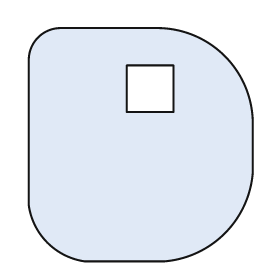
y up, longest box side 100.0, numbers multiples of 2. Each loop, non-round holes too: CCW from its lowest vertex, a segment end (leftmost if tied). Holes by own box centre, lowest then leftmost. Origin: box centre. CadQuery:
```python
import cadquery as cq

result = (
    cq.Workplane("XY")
    .moveTo(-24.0, -50.0)
    .lineTo(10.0, -50.0)
    .threePointArc((36.0, -38.0), (48.0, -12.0))
    .lineTo(48.0, 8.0)
    .threePointArc((36.0, 38.0), (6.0, 50.0))
    .lineTo(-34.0, 50.0)
    .threePointArc((-44.0, 46.0), (-48.0, 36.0))
    .lineTo(-48.0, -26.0)
    .threePointArc((-40.0, -42.0), (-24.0, -50.0))
    .close()
    .moveTo(-6.0, 14.0)
    .lineTo(14.0, 14.0)
    .lineTo(14.0, 34.0)
    .lineTo(-6.0, 34.0)
    .close()
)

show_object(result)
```